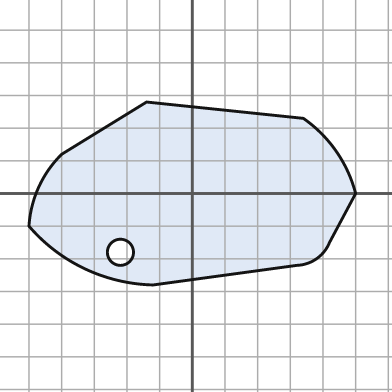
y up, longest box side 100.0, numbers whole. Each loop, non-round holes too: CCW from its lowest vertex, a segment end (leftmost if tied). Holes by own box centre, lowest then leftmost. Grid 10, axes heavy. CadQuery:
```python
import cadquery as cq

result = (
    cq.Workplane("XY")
    .moveTo(-12.0, -28.0)
    .lineTo(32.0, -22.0)
    .threePointArc((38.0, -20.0), (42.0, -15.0))
    .lineTo(50.0, 0.0)
    .threePointArc((44.0, 13.0), (34.0, 23.0))
    .lineTo(-14.0, 28.0)
    .lineTo(-40.0, 12.0)
    .threePointArc((-47.0, 2.0), (-50.0, -10.0))
    .threePointArc((-33.0, -23.0), (-12.0, -28.0))
    .close()
    .moveTo(-22.0, -18.0)
    .circle(4.0)
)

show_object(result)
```